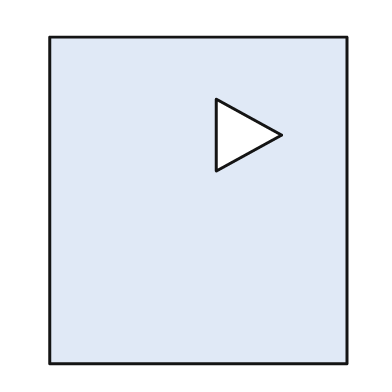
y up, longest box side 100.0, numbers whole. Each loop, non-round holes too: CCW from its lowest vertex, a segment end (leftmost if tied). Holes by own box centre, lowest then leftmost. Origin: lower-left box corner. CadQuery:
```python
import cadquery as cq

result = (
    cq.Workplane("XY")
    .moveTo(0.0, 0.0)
    .lineTo(91.0, 0.0)
    .lineTo(91.0, 100.0)
    .lineTo(0.0, 100.0)
    .close()
    .moveTo(51.0, 59.0)
    .lineTo(71.0, 70.0)
    .lineTo(51.0, 81.0)
    .close()
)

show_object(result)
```